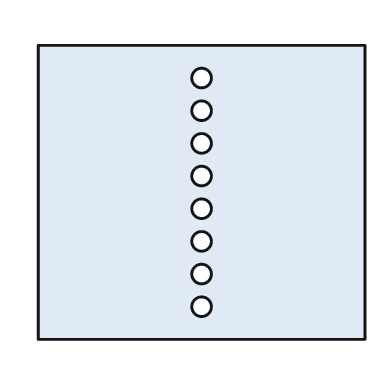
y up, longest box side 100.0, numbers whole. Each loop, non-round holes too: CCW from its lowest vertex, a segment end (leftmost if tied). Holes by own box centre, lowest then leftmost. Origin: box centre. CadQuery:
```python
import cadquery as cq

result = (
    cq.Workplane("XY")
    .moveTo(-50.0, -45.0)
    .lineTo(50.0, -45.0)
    .lineTo(50.0, 45.0)
    .lineTo(-50.0, 45.0)
    .close()
    .moveTo(0.0, -35.0)
    .circle(3.0)
    .moveTo(0.0, -25.0)
    .circle(3.0)
    .moveTo(0.0, -15.0)
    .circle(3.0)
    .moveTo(0.0, -5.0)
    .circle(3.0)
    .moveTo(0.0, 5.0)
    .circle(3.0)
    .moveTo(0.0, 15.0)
    .circle(3.0)
    .moveTo(0.0, 25.0)
    .circle(3.0)
    .moveTo(0.0, 35.0)
    .circle(3.0)
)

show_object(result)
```